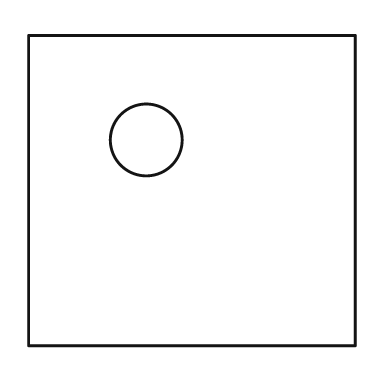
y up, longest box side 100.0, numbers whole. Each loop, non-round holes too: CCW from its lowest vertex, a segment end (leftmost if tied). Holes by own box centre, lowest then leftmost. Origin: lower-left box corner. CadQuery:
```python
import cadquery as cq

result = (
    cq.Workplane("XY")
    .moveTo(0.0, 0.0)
    .lineTo(100.0, 0.0)
    .lineTo(100.0, 95.0)
    .lineTo(0.0, 95.0)
    .close()
    .moveTo(36.0, 63.0)
    .circle(11.0)
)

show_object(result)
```